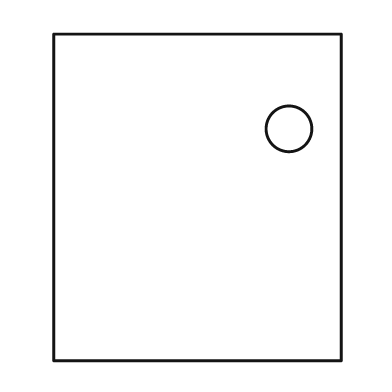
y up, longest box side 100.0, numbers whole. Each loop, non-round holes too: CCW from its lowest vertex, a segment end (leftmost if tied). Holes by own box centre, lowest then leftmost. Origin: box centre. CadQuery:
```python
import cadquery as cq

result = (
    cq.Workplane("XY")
    .moveTo(-44.0, -50.0)
    .lineTo(44.0, -50.0)
    .lineTo(44.0, 50.0)
    .lineTo(-44.0, 50.0)
    .close()
    .moveTo(28.0, 21.0)
    .circle(7.0)
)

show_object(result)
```